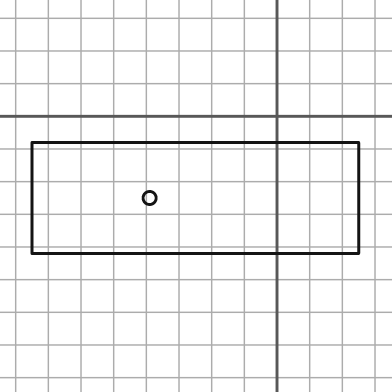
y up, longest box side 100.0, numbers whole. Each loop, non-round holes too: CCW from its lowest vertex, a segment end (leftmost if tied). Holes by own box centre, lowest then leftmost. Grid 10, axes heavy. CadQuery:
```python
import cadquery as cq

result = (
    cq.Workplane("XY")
    .moveTo(-75.0, -42.0)
    .lineTo(25.0, -42.0)
    .lineTo(25.0, -8.0)
    .lineTo(-75.0, -8.0)
    .close()
    .moveTo(-39.0, -25.0)
    .circle(2.0)
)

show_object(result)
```